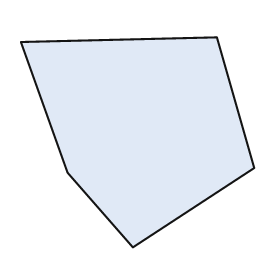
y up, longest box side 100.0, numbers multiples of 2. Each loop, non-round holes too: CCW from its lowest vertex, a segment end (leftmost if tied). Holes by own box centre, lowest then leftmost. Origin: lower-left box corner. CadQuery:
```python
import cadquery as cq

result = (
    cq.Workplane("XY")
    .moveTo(48.0, 0.0)
    .lineTo(100.0, 34.0)
    .lineTo(84.0, 90.0)
    .lineTo(0.0, 88.0)
    .lineTo(20.0, 32.0)
    .close()
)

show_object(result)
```